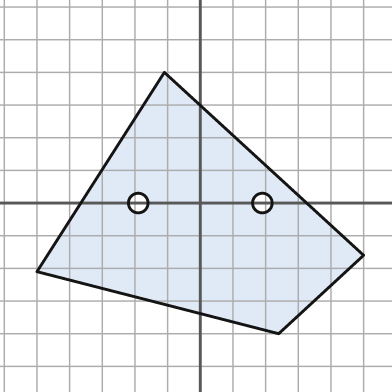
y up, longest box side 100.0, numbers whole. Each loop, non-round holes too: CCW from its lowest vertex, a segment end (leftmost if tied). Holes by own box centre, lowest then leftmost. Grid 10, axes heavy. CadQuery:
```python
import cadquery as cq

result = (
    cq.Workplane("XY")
    .moveTo(24.0, -40.0)
    .lineTo(50.0, -16.0)
    .lineTo(-11.0, 40.0)
    .lineTo(-50.0, -21.0)
    .close()
    .moveTo(-19.0, 0.0)
    .circle(3.0)
    .moveTo(19.0, 0.0)
    .circle(3.0)
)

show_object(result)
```